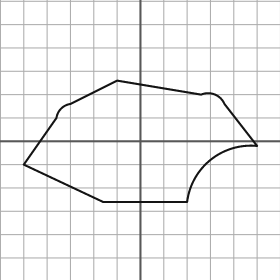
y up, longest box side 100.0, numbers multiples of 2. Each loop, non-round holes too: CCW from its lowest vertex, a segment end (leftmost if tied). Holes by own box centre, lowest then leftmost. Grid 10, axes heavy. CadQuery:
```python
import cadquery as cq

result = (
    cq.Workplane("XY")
    .moveTo(-16.0, -26.0)
    .lineTo(20.0, -26.0)
    .threePointArc((30.0, -8.0), (50.0, -2.0))
    .lineTo(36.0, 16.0)
    .threePointArc((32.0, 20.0), (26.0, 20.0))
    .lineTo(-10.0, 26.0)
    .lineTo(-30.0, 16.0)
    .threePointArc((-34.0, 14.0), (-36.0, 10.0))
    .lineTo(-50.0, -10.0)
    .close()
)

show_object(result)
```